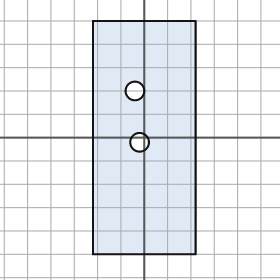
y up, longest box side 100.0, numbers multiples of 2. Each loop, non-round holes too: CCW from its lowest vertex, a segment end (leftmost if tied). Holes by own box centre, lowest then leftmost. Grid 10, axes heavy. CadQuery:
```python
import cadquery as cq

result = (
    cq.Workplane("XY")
    .moveTo(-22.0, -50.0)
    .lineTo(22.0, -50.0)
    .lineTo(22.0, 50.0)
    .lineTo(-22.0, 50.0)
    .close()
    .moveTo(-2.0, -2.0)
    .circle(4.0)
    .moveTo(-4.0, 20.0)
    .circle(4.0)
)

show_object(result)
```